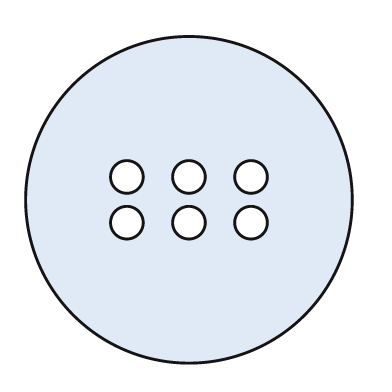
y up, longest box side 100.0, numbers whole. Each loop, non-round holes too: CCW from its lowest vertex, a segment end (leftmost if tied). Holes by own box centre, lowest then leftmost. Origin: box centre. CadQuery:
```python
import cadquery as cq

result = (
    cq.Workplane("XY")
    .moveTo(0.0, 0.0)
    .circle(50.0)
    .moveTo(-19.0, -7.0)
    .circle(5.0)
    .moveTo(0.0, -7.0)
    .circle(5.0)
    .moveTo(19.0, -7.0)
    .circle(5.0)
    .moveTo(-19.0, 7.0)
    .circle(5.0)
    .moveTo(0.0, 7.0)
    .circle(5.0)
    .moveTo(19.0, 7.0)
    .circle(5.0)
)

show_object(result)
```